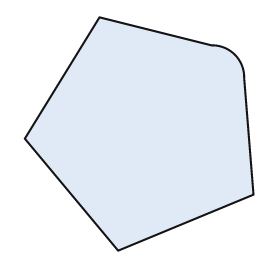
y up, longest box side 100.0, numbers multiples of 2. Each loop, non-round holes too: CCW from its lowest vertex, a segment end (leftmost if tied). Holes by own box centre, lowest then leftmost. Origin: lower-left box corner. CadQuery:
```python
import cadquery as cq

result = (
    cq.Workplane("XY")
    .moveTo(40.0, 0.0)
    .lineTo(98.0, 24.0)
    .lineTo(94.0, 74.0)
    .threePointArc((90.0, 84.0), (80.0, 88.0))
    .lineTo(32.0, 100.0)
    .lineTo(0.0, 48.0)
    .close()
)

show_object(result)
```